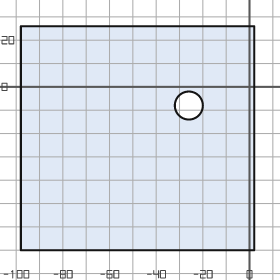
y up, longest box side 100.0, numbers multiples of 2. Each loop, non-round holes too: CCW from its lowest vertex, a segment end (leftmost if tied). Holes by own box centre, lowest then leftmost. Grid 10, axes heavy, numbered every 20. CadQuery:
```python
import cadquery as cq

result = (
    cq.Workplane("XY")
    .moveTo(-98.0, -70.0)
    .lineTo(2.0, -70.0)
    .lineTo(2.0, 26.0)
    .lineTo(-98.0, 26.0)
    .close()
    .moveTo(-26.0, -8.0)
    .circle(6.0)
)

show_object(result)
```